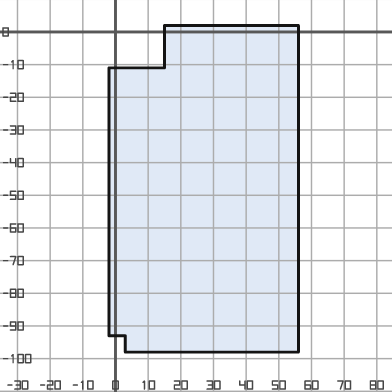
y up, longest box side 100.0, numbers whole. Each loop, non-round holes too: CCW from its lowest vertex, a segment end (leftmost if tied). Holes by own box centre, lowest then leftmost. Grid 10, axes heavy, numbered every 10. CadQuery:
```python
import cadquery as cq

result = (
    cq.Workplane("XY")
    .moveTo(3.0, -98.0)
    .lineTo(56.0, -98.0)
    .lineTo(56.0, 2.0)
    .lineTo(15.0, 2.0)
    .lineTo(15.0, -11.0)
    .lineTo(-2.0, -11.0)
    .lineTo(-2.0, -93.0)
    .lineTo(3.0, -93.0)
    .close()
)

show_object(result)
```